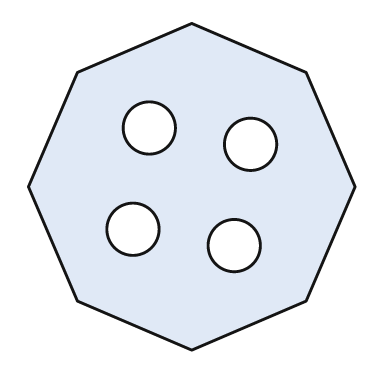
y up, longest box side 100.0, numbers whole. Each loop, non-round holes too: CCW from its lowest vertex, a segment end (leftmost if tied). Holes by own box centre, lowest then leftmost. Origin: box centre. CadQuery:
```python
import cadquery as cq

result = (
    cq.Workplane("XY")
    .moveTo(0.0, -50.0)
    .lineTo(35.0, -35.0)
    .lineTo(50.0, 0.0)
    .lineTo(35.0, 35.0)
    .lineTo(0.0, 50.0)
    .lineTo(-35.0, 35.0)
    .lineTo(-50.0, 0.0)
    .lineTo(-35.0, -35.0)
    .close()
    .moveTo(13.0, -18.0)
    .circle(8.0)
    .moveTo(-18.0, -13.0)
    .circle(8.0)
    .moveTo(18.0, 13.0)
    .circle(8.0)
    .moveTo(-13.0, 18.0)
    .circle(8.0)
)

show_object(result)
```